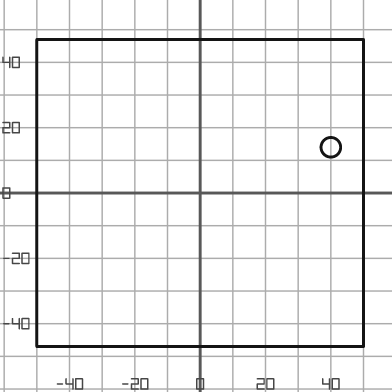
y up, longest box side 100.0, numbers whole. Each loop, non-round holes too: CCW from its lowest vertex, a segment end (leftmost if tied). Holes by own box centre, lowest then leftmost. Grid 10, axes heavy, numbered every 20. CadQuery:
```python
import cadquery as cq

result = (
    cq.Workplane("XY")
    .moveTo(-50.0, -47.0)
    .lineTo(50.0, -47.0)
    .lineTo(50.0, 47.0)
    .lineTo(-50.0, 47.0)
    .close()
    .moveTo(40.0, 14.0)
    .circle(3.0)
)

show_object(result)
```